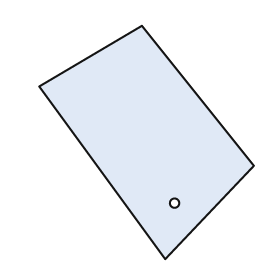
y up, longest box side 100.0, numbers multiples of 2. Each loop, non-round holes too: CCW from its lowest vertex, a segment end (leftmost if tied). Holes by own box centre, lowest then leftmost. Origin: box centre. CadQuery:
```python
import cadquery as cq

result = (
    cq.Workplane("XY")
    .moveTo(8.0, -50.0)
    .lineTo(46.0, -10.0)
    .lineTo(-2.0, 50.0)
    .lineTo(-46.0, 24.0)
    .close()
    .moveTo(12.0, -26.0)
    .circle(2.0)
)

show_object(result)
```